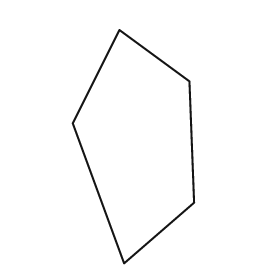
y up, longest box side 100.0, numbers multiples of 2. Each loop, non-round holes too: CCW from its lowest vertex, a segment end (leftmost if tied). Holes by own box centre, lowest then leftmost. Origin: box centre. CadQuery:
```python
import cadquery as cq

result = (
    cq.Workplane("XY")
    .moveTo(-4.0, -50.0)
    .lineTo(26.0, -24.0)
    .lineTo(24.0, 28.0)
    .lineTo(-6.0, 50.0)
    .lineTo(-26.0, 10.0)
    .close()
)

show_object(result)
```